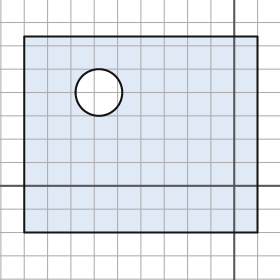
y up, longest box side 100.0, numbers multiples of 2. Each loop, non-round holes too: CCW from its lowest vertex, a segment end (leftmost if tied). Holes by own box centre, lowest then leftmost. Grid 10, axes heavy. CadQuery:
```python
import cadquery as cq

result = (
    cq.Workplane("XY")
    .moveTo(-90.0, -20.0)
    .lineTo(10.0, -20.0)
    .lineTo(10.0, 64.0)
    .lineTo(-90.0, 64.0)
    .close()
    .moveTo(-58.0, 40.0)
    .circle(10.0)
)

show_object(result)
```